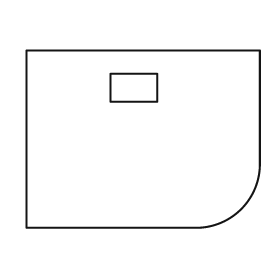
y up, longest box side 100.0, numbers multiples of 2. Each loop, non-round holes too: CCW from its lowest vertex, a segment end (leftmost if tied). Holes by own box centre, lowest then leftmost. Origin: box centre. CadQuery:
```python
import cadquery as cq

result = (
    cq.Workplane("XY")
    .moveTo(-50.0, -38.0)
    .lineTo(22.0, -38.0)
    .threePointArc((42.0, -30.0), (50.0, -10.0))
    .lineTo(50.0, 38.0)
    .lineTo(-50.0, 38.0)
    .close()
    .moveTo(-14.0, 16.0)
    .lineTo(6.0, 16.0)
    .lineTo(6.0, 28.0)
    .lineTo(-14.0, 28.0)
    .close()
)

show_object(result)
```